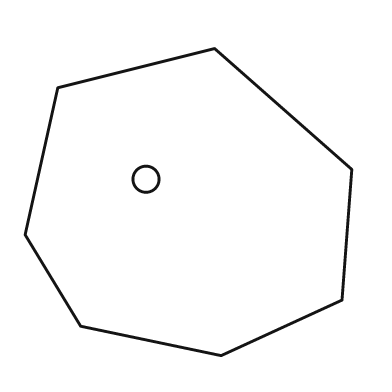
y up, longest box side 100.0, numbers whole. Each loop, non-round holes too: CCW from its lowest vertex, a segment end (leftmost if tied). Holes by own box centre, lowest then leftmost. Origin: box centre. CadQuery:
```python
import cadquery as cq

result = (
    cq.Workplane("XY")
    .moveTo(10.0, -47.0)
    .lineTo(47.0, -30.0)
    .lineTo(50.0, 10.0)
    .lineTo(8.0, 47.0)
    .lineTo(-40.0, 35.0)
    .lineTo(-50.0, -10.0)
    .lineTo(-33.0, -38.0)
    .close()
    .moveTo(-13.0, 7.0)
    .circle(4.0)
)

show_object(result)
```